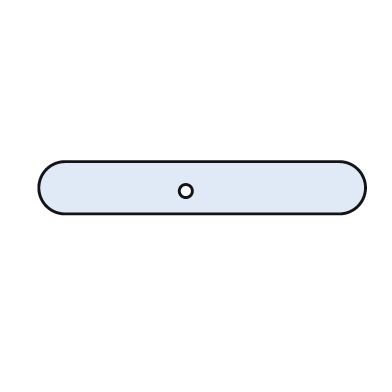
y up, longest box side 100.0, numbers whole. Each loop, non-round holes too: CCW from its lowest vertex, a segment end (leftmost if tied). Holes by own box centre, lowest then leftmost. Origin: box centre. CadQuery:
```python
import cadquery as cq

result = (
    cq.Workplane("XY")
    .moveTo(-42.0, -8.0)
    .lineTo(42.0, -8.0)
    .threePointArc((50.0, 0.0), (42.0, 8.0))
    .lineTo(-42.0, 8.0)
    .threePointArc((-50.0, 0.0), (-42.0, -8.0))
    .close()
    .moveTo(-5.0, -1.0)
    .circle(2.0)
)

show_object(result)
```